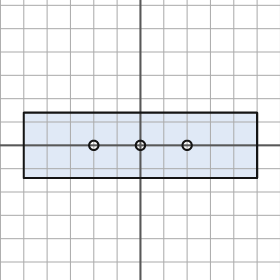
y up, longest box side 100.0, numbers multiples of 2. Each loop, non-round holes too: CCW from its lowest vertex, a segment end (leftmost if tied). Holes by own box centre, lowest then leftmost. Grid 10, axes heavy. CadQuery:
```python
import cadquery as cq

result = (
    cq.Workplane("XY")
    .moveTo(-50.0, -14.0)
    .lineTo(50.0, -14.0)
    .lineTo(50.0, 14.0)
    .lineTo(-50.0, 14.0)
    .close()
    .moveTo(-20.0, 0.0)
    .circle(2.0)
    .moveTo(0.0, 0.0)
    .circle(2.0)
    .moveTo(20.0, 0.0)
    .circle(2.0)
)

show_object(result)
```